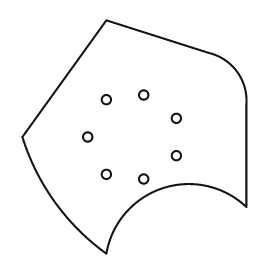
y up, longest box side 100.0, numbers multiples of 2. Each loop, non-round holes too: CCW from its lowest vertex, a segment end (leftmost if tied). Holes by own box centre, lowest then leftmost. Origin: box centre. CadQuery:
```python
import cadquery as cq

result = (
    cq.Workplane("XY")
    .moveTo(-12.0, -50.0)
    .threePointArc((12.0, -22.0), (48.0, -30.0))
    .lineTo(48.0, 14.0)
    .threePointArc((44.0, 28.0), (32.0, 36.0))
    .lineTo(-12.0, 50.0)
    .lineTo(-48.0, 0.0)
    .threePointArc((-34.0, -28.0), (-12.0, -50.0))
    .close()
    .moveTo(4.0, -18.0)
    .circle(2.0)
    .moveTo(-12.0, -16.0)
    .circle(2.0)
    .moveTo(18.0, -8.0)
    .circle(2.0)
    .moveTo(-20.0, 0.0)
    .circle(2.0)
    .moveTo(18.0, 8.0)
    .circle(2.0)
    .moveTo(-12.0, 16.0)
    .circle(2.0)
    .moveTo(4.0, 18.0)
    .circle(2.0)
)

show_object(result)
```